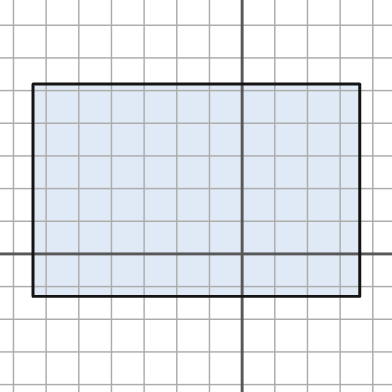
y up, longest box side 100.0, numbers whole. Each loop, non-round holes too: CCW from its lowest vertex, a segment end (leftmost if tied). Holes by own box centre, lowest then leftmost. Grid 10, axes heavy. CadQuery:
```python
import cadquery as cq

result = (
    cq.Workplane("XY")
    .moveTo(-64.0, -13.0)
    .lineTo(36.0, -13.0)
    .lineTo(36.0, 52.0)
    .lineTo(-64.0, 52.0)
    .close()
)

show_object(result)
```